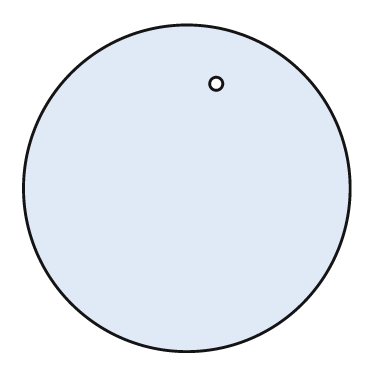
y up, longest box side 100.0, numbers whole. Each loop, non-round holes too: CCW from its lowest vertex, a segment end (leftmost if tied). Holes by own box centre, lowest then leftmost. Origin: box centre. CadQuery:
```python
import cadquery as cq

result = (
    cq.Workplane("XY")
    .moveTo(0.0, 0.0)
    .circle(50.0)
    .moveTo(9.0, 32.0)
    .circle(2.0)
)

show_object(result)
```